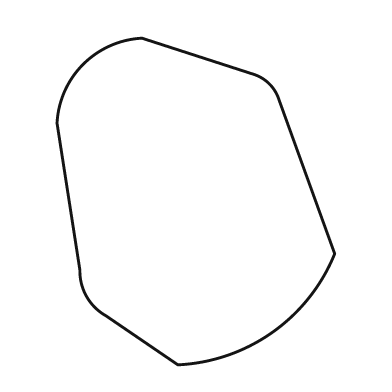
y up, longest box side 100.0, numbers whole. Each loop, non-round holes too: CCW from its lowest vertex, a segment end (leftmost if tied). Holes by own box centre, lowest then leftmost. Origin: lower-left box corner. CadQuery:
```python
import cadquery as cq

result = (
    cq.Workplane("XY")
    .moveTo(37.0, 0.0)
    .threePointArc((66.0, 10.0), (85.0, 34.0))
    .lineTo(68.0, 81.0)
    .threePointArc((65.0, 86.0), (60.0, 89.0))
    .lineTo(26.0, 100.0)
    .threePointArc((8.0, 92.0), (0.0, 74.0))
    .lineTo(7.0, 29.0)
    .threePointArc((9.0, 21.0), (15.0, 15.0))
    .close()
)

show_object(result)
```